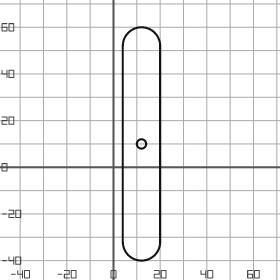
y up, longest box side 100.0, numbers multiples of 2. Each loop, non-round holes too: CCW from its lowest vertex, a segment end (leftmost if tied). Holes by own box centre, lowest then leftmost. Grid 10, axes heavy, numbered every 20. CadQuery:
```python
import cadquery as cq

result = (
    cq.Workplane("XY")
    .moveTo(4.0, -32.0)
    .threePointArc((12.0, -40.0), (20.0, -32.0))
    .lineTo(20.0, 52.0)
    .threePointArc((12.0, 60.0), (4.0, 52.0))
    .close()
    .moveTo(12.0, 10.0)
    .circle(2.0)
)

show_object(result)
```